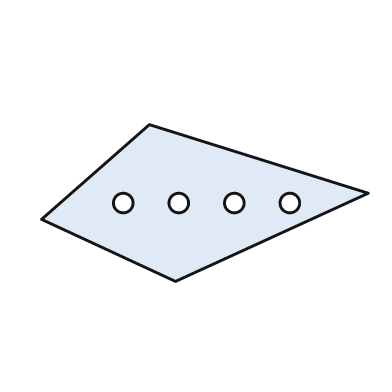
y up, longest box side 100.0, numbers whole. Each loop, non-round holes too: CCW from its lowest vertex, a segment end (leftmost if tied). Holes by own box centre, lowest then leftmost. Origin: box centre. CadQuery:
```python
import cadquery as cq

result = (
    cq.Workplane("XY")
    .moveTo(-9.0, -24.0)
    .lineTo(50.0, 3.0)
    .lineTo(-17.0, 24.0)
    .lineTo(-50.0, -5.0)
    .close()
    .moveTo(-25.0, 0.0)
    .circle(3.0)
    .moveTo(-8.0, 0.0)
    .circle(3.0)
    .moveTo(9.0, 0.0)
    .circle(3.0)
    .moveTo(26.0, 0.0)
    .circle(3.0)
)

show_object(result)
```